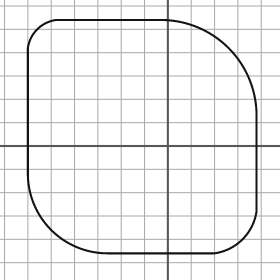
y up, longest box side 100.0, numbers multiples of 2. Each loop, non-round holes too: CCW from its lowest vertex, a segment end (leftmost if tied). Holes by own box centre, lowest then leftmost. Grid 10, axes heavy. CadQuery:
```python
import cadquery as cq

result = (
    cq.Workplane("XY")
    .moveTo(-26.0, -46.0)
    .lineTo(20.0, -46.0)
    .threePointArc((32.0, -40.0), (38.0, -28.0))
    .lineTo(38.0, 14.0)
    .threePointArc((26.0, 42.0), (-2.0, 54.0))
    .lineTo(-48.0, 54.0)
    .threePointArc((-56.0, 50.0), (-60.0, 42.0))
    .lineTo(-60.0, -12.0)
    .threePointArc((-50.0, -36.0), (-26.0, -46.0))
    .close()
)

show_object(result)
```